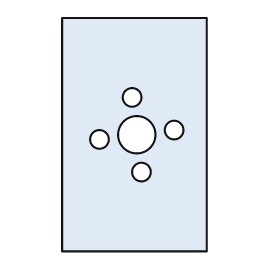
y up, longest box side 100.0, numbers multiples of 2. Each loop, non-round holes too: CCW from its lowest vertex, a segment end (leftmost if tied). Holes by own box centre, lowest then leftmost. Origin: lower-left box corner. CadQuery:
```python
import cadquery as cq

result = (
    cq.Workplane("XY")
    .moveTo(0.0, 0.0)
    .lineTo(62.0, 0.0)
    .lineTo(62.0, 100.0)
    .lineTo(0.0, 100.0)
    .close()
    .moveTo(34.0, 34.0)
    .circle(4.0)
    .moveTo(16.0, 48.0)
    .circle(4.0)
    .moveTo(32.0, 50.0)
    .circle(8.0)
    .moveTo(48.0, 52.0)
    .circle(4.0)
    .moveTo(30.0, 66.0)
    .circle(4.0)
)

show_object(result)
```